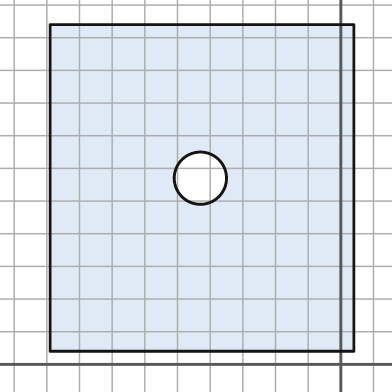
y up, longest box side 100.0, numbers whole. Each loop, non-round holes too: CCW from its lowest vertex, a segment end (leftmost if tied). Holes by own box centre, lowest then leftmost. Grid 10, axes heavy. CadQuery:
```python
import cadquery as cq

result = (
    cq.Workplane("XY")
    .moveTo(-89.0, 4.0)
    .lineTo(4.0, 4.0)
    .lineTo(4.0, 104.0)
    .lineTo(-89.0, 104.0)
    .close()
    .moveTo(-43.0, 57.0)
    .circle(8.0)
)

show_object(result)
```